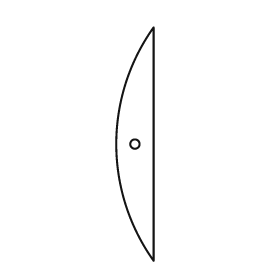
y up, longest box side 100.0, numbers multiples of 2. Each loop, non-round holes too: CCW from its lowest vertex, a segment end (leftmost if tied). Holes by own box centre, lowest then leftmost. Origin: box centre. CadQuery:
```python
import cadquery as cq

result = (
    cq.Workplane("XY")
    .moveTo(8.0, -50.0)
    .lineTo(8.0, 50.0)
    .threePointArc((-8.0, 0.0), (8.0, -50.0))
    .close()
    .moveTo(0.0, 0.0)
    .circle(2.0)
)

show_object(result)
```